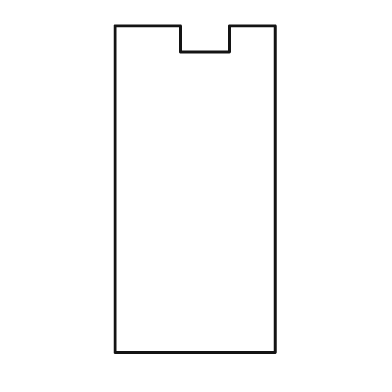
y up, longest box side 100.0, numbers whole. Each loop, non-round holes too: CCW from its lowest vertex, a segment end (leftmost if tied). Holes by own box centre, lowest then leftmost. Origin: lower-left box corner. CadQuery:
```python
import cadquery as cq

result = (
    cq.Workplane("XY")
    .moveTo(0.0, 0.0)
    .lineTo(49.0, 0.0)
    .lineTo(49.0, 100.0)
    .lineTo(35.0, 100.0)
    .lineTo(35.0, 92.0)
    .lineTo(20.0, 92.0)
    .lineTo(20.0, 100.0)
    .lineTo(0.0, 100.0)
    .close()
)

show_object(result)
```